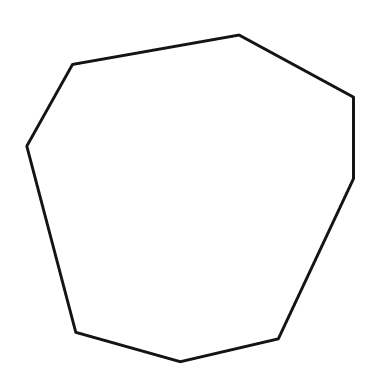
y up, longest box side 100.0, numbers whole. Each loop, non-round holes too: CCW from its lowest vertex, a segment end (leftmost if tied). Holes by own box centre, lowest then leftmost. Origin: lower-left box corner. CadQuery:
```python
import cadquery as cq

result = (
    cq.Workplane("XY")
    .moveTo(47.0, 0.0)
    .lineTo(77.0, 7.0)
    .lineTo(100.0, 56.0)
    .lineTo(100.0, 81.0)
    .lineTo(65.0, 100.0)
    .lineTo(14.0, 91.0)
    .lineTo(0.0, 66.0)
    .lineTo(15.0, 9.0)
    .close()
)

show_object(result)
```